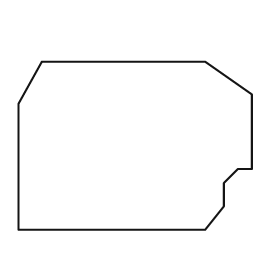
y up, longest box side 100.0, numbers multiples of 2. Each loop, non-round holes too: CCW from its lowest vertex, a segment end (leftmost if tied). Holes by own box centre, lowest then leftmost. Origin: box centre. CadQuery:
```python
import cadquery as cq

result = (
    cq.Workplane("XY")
    .moveTo(-50.0, -36.0)
    .lineTo(30.0, -36.0)
    .lineTo(38.0, -26.0)
    .lineTo(38.0, -16.0)
    .lineTo(44.0, -10.0)
    .lineTo(50.0, -10.0)
    .lineTo(50.0, 22.0)
    .lineTo(30.0, 36.0)
    .lineTo(-40.0, 36.0)
    .lineTo(-50.0, 18.0)
    .close()
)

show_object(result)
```